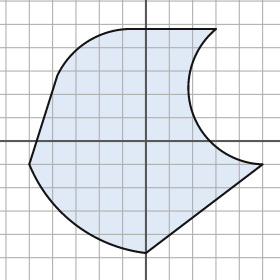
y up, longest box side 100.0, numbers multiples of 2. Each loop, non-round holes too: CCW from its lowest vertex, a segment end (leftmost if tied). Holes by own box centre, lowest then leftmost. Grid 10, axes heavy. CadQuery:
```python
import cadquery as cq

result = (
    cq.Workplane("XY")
    .moveTo(0.0, -48.0)
    .lineTo(50.0, -10.0)
    .threePointArc((20.0, 12.0), (30.0, 48.0))
    .lineTo(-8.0, 48.0)
    .threePointArc((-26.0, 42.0), (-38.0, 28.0))
    .lineTo(-50.0, -10.0)
    .threePointArc((-30.0, -36.0), (0.0, -48.0))
    .close()
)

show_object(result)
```